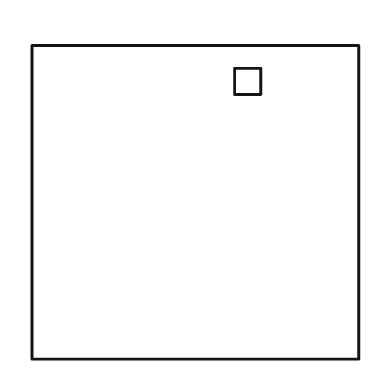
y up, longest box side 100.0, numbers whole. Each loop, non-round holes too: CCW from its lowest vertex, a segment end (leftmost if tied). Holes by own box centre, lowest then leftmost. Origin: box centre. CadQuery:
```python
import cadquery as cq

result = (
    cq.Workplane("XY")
    .moveTo(-50.0, -48.0)
    .lineTo(50.0, -48.0)
    .lineTo(50.0, 48.0)
    .lineTo(-50.0, 48.0)
    .close()
    .moveTo(12.0, 33.0)
    .lineTo(20.0, 33.0)
    .lineTo(20.0, 41.0)
    .lineTo(12.0, 41.0)
    .close()
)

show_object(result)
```